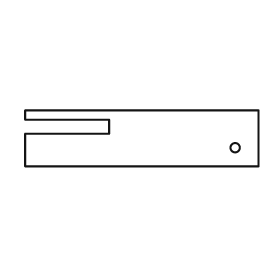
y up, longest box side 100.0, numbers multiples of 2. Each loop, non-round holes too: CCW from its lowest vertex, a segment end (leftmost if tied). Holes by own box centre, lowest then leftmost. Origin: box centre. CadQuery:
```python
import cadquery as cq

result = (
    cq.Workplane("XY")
    .moveTo(-50.0, -12.0)
    .lineTo(50.0, -12.0)
    .lineTo(50.0, 12.0)
    .lineTo(-50.0, 12.0)
    .lineTo(-50.0, 8.0)
    .lineTo(-14.0, 8.0)
    .lineTo(-14.0, 2.0)
    .lineTo(-50.0, 2.0)
    .close()
    .moveTo(40.0, -4.0)
    .circle(2.0)
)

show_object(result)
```